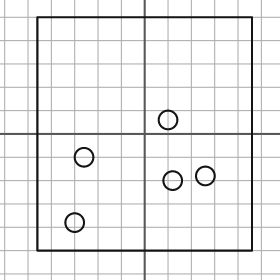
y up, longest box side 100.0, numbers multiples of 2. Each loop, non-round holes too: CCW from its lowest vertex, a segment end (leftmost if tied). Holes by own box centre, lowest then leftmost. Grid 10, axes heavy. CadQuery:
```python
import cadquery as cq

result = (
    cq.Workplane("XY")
    .moveTo(-46.0, -50.0)
    .lineTo(46.0, -50.0)
    .lineTo(46.0, 50.0)
    .lineTo(-46.0, 50.0)
    .close()
    .moveTo(-30.0, -38.0)
    .circle(4.0)
    .moveTo(12.0, -20.0)
    .circle(4.0)
    .moveTo(26.0, -18.0)
    .circle(4.0)
    .moveTo(-26.0, -10.0)
    .circle(4.0)
    .moveTo(10.0, 6.0)
    .circle(4.0)
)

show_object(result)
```